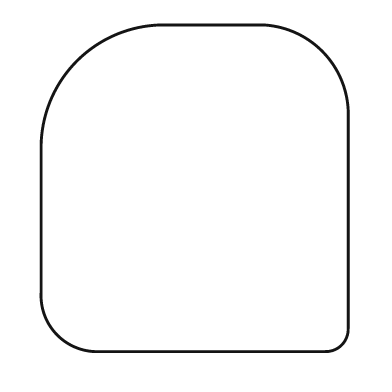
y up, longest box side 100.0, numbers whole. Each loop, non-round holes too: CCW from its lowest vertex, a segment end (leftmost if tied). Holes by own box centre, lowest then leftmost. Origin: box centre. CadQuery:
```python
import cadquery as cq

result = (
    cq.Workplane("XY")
    .moveTo(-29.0, -50.0)
    .lineTo(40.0, -50.0)
    .threePointArc((45.0, -48.0), (47.0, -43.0))
    .lineTo(47.0, 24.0)
    .threePointArc((39.0, 42.0), (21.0, 50.0))
    .lineTo(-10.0, 50.0)
    .threePointArc((-36.0, 39.0), (-47.0, 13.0))
    .lineTo(-47.0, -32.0)
    .threePointArc((-42.0, -45.0), (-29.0, -50.0))
    .close()
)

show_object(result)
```